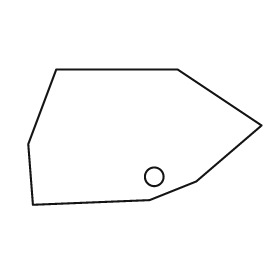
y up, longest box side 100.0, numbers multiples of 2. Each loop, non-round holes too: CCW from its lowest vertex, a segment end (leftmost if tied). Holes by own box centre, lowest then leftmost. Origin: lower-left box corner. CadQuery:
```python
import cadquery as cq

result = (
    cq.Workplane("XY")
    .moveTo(2.0, 0.0)
    .lineTo(52.0, 2.0)
    .lineTo(72.0, 10.0)
    .lineTo(100.0, 34.0)
    .lineTo(64.0, 58.0)
    .lineTo(12.0, 58.0)
    .lineTo(0.0, 26.0)
    .close()
    .moveTo(54.0, 12.0)
    .circle(4.0)
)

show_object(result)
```